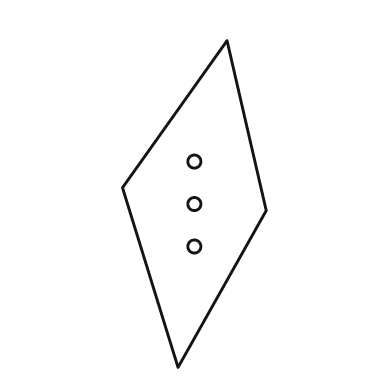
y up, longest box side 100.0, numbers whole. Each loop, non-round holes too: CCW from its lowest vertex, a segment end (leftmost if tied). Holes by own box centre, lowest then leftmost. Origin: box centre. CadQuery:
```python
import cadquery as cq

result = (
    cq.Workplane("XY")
    .moveTo(-5.0, -50.0)
    .lineTo(22.0, -2.0)
    .lineTo(10.0, 50.0)
    .lineTo(-22.0, 5.0)
    .close()
    .moveTo(0.0, -13.0)
    .circle(2.0)
    .moveTo(0.0, 0.0)
    .circle(2.0)
    .moveTo(0.0, 13.0)
    .circle(2.0)
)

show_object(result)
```